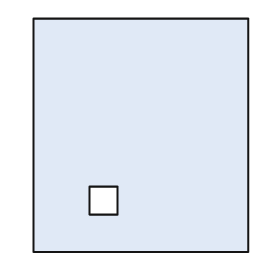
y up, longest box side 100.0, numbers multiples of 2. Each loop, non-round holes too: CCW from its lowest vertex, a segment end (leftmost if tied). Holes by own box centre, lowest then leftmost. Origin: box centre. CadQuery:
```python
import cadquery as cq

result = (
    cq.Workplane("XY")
    .moveTo(-46.0, -50.0)
    .lineTo(46.0, -50.0)
    .lineTo(46.0, 50.0)
    .lineTo(-46.0, 50.0)
    .close()
    .moveTo(-22.0, -34.0)
    .lineTo(-10.0, -34.0)
    .lineTo(-10.0, -22.0)
    .lineTo(-22.0, -22.0)
    .close()
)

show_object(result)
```